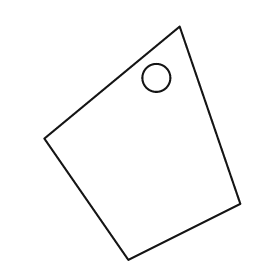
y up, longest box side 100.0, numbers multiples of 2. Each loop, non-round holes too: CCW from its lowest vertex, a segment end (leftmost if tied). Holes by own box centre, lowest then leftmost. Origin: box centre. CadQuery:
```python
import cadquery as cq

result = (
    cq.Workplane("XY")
    .moveTo(-6.0, -50.0)
    .lineTo(42.0, -26.0)
    .lineTo(16.0, 50.0)
    .lineTo(-42.0, 2.0)
    .close()
    .moveTo(6.0, 28.0)
    .circle(6.0)
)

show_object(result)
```